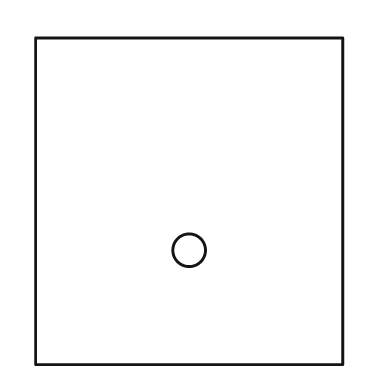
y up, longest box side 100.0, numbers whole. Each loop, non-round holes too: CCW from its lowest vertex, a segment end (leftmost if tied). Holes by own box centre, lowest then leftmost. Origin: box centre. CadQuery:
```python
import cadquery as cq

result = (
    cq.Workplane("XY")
    .moveTo(-47.0, -50.0)
    .lineTo(47.0, -50.0)
    .lineTo(47.0, 50.0)
    .lineTo(-47.0, 50.0)
    .close()
    .moveTo(0.0, -15.0)
    .circle(5.0)
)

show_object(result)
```